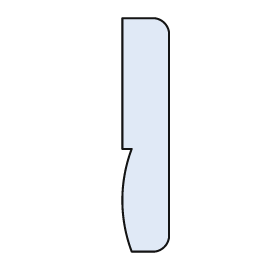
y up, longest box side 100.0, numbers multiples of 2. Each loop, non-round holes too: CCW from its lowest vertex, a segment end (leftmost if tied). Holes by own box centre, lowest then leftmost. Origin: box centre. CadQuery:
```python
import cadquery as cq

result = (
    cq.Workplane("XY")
    .moveTo(-6.0, -50.0)
    .lineTo(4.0, -50.0)
    .threePointArc((8.0, -48.0), (10.0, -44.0))
    .lineTo(10.0, 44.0)
    .threePointArc((8.0, 48.0), (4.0, 50.0))
    .lineTo(-10.0, 50.0)
    .lineTo(-10.0, -6.0)
    .lineTo(-6.0, -6.0)
    .threePointArc((-10.0, -28.0), (-6.0, -50.0))
    .close()
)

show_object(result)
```